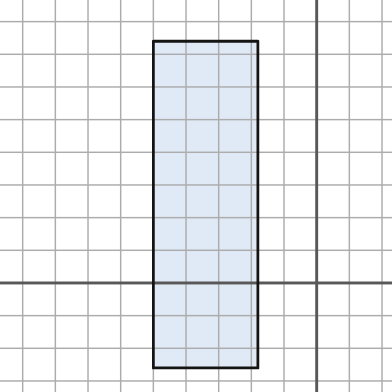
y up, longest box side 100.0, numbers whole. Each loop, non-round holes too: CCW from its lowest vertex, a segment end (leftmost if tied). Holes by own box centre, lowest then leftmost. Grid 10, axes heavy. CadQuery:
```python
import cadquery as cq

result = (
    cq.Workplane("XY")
    .moveTo(-50.0, -26.0)
    .lineTo(-18.0, -26.0)
    .lineTo(-18.0, 74.0)
    .lineTo(-50.0, 74.0)
    .close()
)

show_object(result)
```